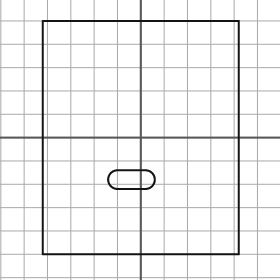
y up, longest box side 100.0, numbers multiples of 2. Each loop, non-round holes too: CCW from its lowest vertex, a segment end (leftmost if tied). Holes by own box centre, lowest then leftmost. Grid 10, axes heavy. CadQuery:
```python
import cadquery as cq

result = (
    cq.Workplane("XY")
    .moveTo(-42.0, -50.0)
    .lineTo(42.0, -50.0)
    .lineTo(42.0, 50.0)
    .lineTo(-42.0, 50.0)
    .close()
    .moveTo(-10.0, -22.0)
    .lineTo(2.0, -22.0)
    .threePointArc((6.0, -18.0), (2.0, -14.0))
    .lineTo(-10.0, -14.0)
    .threePointArc((-14.0, -18.0), (-10.0, -22.0))
    .close()
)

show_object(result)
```